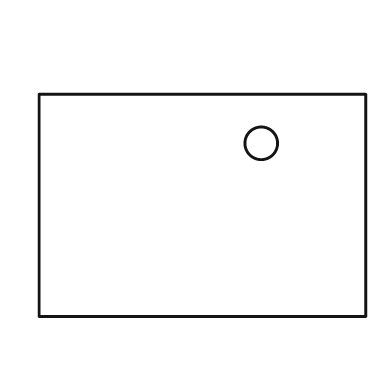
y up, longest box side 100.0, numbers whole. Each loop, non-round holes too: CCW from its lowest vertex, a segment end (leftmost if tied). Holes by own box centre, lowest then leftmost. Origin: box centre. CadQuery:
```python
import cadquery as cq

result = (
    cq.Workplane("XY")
    .moveTo(-50.0, -34.0)
    .lineTo(50.0, -34.0)
    .lineTo(50.0, 34.0)
    .lineTo(-50.0, 34.0)
    .close()
    .moveTo(18.0, 19.0)
    .circle(5.0)
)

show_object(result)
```